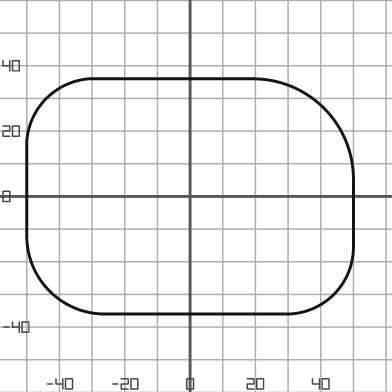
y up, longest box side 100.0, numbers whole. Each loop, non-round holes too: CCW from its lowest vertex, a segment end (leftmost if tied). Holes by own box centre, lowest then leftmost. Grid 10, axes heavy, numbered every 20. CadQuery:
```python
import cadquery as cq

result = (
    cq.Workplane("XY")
    .moveTo(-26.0, -36.0)
    .lineTo(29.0, -36.0)
    .threePointArc((44.0, -30.0), (50.0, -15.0))
    .lineTo(50.0, 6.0)
    .threePointArc((41.0, 27.0), (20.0, 36.0))
    .lineTo(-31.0, 36.0)
    .threePointArc((-44.0, 30.0), (-50.0, 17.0))
    .lineTo(-50.0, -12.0)
    .threePointArc((-43.0, -29.0), (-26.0, -36.0))
    .close()
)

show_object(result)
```